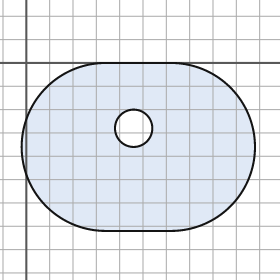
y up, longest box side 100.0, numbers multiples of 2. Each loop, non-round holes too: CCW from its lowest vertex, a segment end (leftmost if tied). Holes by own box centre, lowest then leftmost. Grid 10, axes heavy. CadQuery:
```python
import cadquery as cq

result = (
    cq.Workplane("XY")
    .moveTo(34.0, -72.0)
    .lineTo(62.0, -72.0)
    .threePointArc((98.0, -36.0), (62.0, 0.0))
    .lineTo(34.0, 0.0)
    .threePointArc((-2.0, -36.0), (34.0, -72.0))
    .close()
    .moveTo(46.0, -28.0)
    .circle(8.0)
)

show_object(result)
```